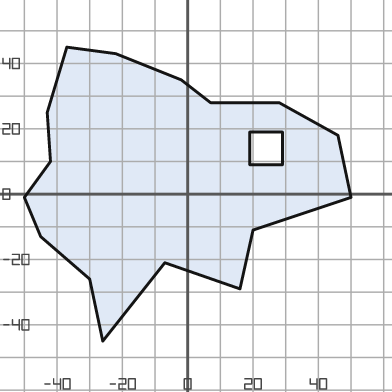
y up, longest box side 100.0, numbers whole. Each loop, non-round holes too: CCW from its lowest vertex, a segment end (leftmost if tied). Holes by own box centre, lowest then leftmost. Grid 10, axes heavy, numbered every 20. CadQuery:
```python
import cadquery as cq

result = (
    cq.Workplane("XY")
    .moveTo(-26.0, -45.0)
    .lineTo(-7.0, -21.0)
    .lineTo(16.0, -29.0)
    .lineTo(20.0, -11.0)
    .lineTo(50.0, -1.0)
    .lineTo(46.0, 18.0)
    .lineTo(28.0, 28.0)
    .lineTo(7.0, 28.0)
    .lineTo(-2.0, 35.0)
    .lineTo(-22.0, 43.0)
    .lineTo(-37.0, 45.0)
    .lineTo(-43.0, 25.0)
    .lineTo(-42.0, 10.0)
    .lineTo(-50.0, -1.0)
    .lineTo(-45.0, -13.0)
    .lineTo(-30.0, -26.0)
    .close()
    .moveTo(19.0, 9.0)
    .lineTo(29.0, 9.0)
    .lineTo(29.0, 19.0)
    .lineTo(19.0, 19.0)
    .close()
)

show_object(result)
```